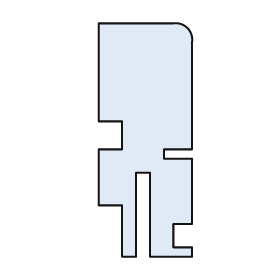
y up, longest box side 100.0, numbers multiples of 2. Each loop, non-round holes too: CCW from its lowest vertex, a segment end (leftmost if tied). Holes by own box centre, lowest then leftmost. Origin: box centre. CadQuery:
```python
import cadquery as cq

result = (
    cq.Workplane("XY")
    .moveTo(-10.0, -50.0)
    .lineTo(-4.0, -50.0)
    .lineTo(-4.0, -14.0)
    .lineTo(2.0, -14.0)
    .lineTo(2.0, -50.0)
    .lineTo(20.0, -50.0)
    .lineTo(20.0, -46.0)
    .lineTo(12.0, -46.0)
    .lineTo(12.0, -36.0)
    .lineTo(20.0, -36.0)
    .lineTo(20.0, -8.0)
    .lineTo(8.0, -8.0)
    .lineTo(8.0, -4.0)
    .lineTo(20.0, -4.0)
    .lineTo(20.0, 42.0)
    .threePointArc((18.0, 48.0), (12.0, 50.0))
    .lineTo(-20.0, 50.0)
    .lineTo(-20.0, 8.0)
    .lineTo(-10.0, 8.0)
    .lineTo(-10.0, -4.0)
    .lineTo(-20.0, -4.0)
    .lineTo(-20.0, -28.0)
    .lineTo(-10.0, -28.0)
    .close()
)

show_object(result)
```